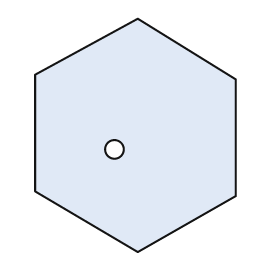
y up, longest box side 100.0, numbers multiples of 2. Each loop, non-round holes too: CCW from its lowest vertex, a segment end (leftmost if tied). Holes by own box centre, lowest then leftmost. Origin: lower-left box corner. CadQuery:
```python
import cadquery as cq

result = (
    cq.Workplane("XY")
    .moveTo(44.0, 0.0)
    .lineTo(86.0, 24.0)
    .lineTo(86.0, 74.0)
    .lineTo(44.0, 100.0)
    .lineTo(0.0, 76.0)
    .lineTo(0.0, 26.0)
    .close()
    .moveTo(34.0, 44.0)
    .circle(4.0)
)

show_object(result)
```